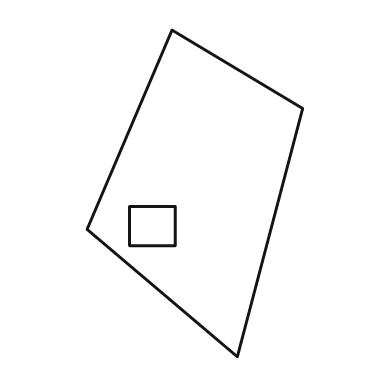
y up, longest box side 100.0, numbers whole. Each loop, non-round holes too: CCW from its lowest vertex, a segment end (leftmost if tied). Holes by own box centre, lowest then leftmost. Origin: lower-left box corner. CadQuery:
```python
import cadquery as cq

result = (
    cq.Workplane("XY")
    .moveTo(46.0, 0.0)
    .lineTo(66.0, 76.0)
    .lineTo(26.0, 100.0)
    .lineTo(0.0, 39.0)
    .close()
    .moveTo(13.0, 34.0)
    .lineTo(27.0, 34.0)
    .lineTo(27.0, 46.0)
    .lineTo(13.0, 46.0)
    .close()
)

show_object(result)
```